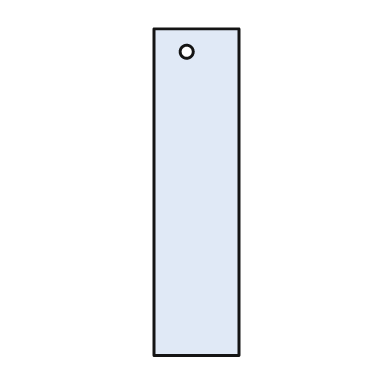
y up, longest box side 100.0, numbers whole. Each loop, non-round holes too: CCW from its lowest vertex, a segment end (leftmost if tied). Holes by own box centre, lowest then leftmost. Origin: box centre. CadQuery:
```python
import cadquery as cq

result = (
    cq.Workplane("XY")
    .moveTo(-13.0, -50.0)
    .lineTo(13.0, -50.0)
    .lineTo(13.0, 50.0)
    .lineTo(-13.0, 50.0)
    .close()
    .moveTo(-3.0, 43.0)
    .circle(2.0)
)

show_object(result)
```